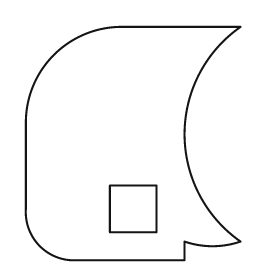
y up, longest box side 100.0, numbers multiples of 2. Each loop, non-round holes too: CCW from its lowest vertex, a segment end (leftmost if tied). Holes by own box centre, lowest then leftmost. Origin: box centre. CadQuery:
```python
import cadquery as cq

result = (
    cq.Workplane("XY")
    .moveTo(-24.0, -50.0)
    .lineTo(22.0, -50.0)
    .lineTo(22.0, -42.0)
    .threePointArc((34.0, -44.0), (46.0, -42.0))
    .threePointArc((22.0, 4.0), (46.0, 50.0))
    .lineTo(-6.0, 50.0)
    .threePointArc((-34.0, 38.0), (-46.0, 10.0))
    .lineTo(-46.0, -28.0)
    .threePointArc((-40.0, -44.0), (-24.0, -50.0))
    .close()
    .moveTo(-10.0, -38.0)
    .lineTo(10.0, -38.0)
    .lineTo(10.0, -18.0)
    .lineTo(-10.0, -18.0)
    .close()
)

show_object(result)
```